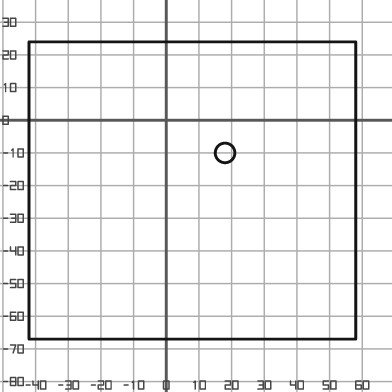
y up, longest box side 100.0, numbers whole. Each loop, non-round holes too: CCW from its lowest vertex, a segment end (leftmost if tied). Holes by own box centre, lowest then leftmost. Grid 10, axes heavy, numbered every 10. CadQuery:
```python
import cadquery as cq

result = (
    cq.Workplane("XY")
    .moveTo(-42.0, -67.0)
    .lineTo(58.0, -67.0)
    .lineTo(58.0, 24.0)
    .lineTo(-42.0, 24.0)
    .close()
    .moveTo(18.0, -10.0)
    .circle(3.0)
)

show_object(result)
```